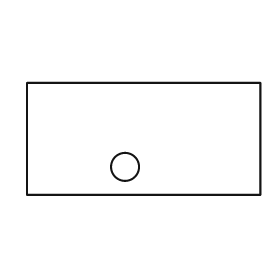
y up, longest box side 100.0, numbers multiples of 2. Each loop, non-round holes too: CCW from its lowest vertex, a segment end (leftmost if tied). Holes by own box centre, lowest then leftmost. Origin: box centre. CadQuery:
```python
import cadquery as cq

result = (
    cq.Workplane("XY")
    .moveTo(-50.0, -24.0)
    .lineTo(50.0, -24.0)
    .lineTo(50.0, 24.0)
    .lineTo(-50.0, 24.0)
    .close()
    .moveTo(-8.0, -12.0)
    .circle(6.0)
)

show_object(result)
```